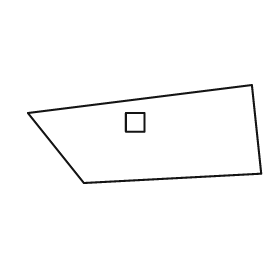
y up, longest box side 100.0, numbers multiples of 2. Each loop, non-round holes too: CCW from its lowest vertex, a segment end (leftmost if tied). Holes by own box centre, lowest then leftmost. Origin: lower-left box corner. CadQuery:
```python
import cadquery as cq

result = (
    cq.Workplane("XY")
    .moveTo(24.0, 0.0)
    .lineTo(100.0, 4.0)
    .lineTo(96.0, 42.0)
    .lineTo(0.0, 30.0)
    .close()
    .moveTo(42.0, 22.0)
    .lineTo(50.0, 22.0)
    .lineTo(50.0, 30.0)
    .lineTo(42.0, 30.0)
    .close()
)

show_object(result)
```